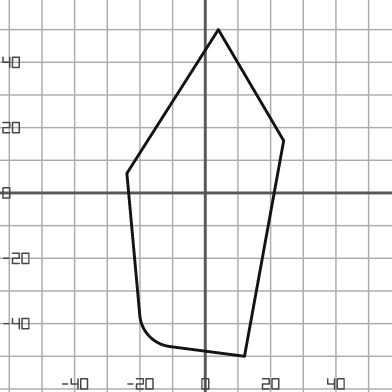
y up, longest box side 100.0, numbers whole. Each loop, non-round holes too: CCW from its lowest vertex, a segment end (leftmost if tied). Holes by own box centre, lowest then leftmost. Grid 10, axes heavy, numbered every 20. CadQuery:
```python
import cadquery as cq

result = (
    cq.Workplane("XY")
    .moveTo(12.0, -50.0)
    .lineTo(24.0, 16.0)
    .lineTo(4.0, 50.0)
    .lineTo(-24.0, 6.0)
    .lineTo(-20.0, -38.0)
    .threePointArc((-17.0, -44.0), (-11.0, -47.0))
    .close()
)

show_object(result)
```